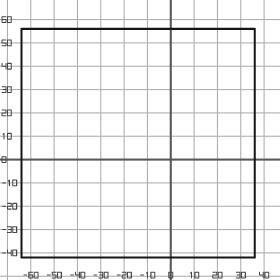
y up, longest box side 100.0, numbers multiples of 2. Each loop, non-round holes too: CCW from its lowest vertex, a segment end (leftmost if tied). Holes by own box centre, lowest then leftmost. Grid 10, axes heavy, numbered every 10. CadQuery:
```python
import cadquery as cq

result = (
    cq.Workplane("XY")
    .moveTo(-64.0, -42.0)
    .lineTo(36.0, -42.0)
    .lineTo(36.0, 56.0)
    .lineTo(-64.0, 56.0)
    .close()
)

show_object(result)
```